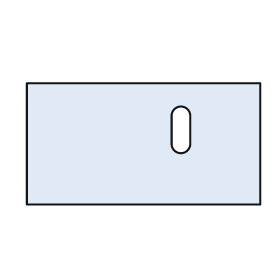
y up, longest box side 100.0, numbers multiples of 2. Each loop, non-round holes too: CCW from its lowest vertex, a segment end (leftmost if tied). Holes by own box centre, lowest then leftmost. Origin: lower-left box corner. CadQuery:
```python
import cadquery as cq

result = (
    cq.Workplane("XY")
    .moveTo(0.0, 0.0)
    .lineTo(100.0, 0.0)
    .lineTo(100.0, 52.0)
    .lineTo(0.0, 52.0)
    .close()
    .moveTo(62.0, 26.0)
    .threePointArc((66.0, 22.0), (70.0, 26.0))
    .lineTo(70.0, 38.0)
    .threePointArc((66.0, 42.0), (62.0, 38.0))
    .close()
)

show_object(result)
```